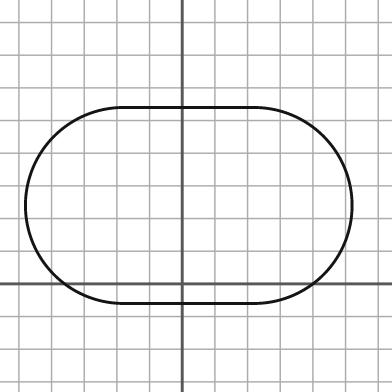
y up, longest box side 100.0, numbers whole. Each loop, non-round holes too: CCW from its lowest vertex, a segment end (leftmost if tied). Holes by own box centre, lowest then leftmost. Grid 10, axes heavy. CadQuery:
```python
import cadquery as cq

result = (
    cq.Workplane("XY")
    .moveTo(-18.0, -6.0)
    .lineTo(22.0, -6.0)
    .threePointArc((52.0, 24.0), (22.0, 54.0))
    .lineTo(-18.0, 54.0)
    .threePointArc((-48.0, 24.0), (-18.0, -6.0))
    .close()
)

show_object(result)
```